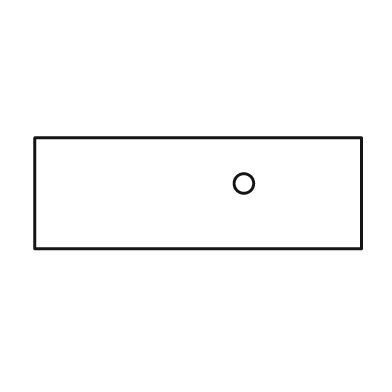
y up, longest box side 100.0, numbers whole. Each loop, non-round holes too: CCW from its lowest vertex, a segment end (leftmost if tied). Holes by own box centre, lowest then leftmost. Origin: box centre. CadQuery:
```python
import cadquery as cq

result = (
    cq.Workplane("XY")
    .moveTo(-50.0, -17.0)
    .lineTo(50.0, -17.0)
    .lineTo(50.0, 17.0)
    .lineTo(-50.0, 17.0)
    .close()
    .moveTo(14.0, 3.0)
    .circle(3.0)
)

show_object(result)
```